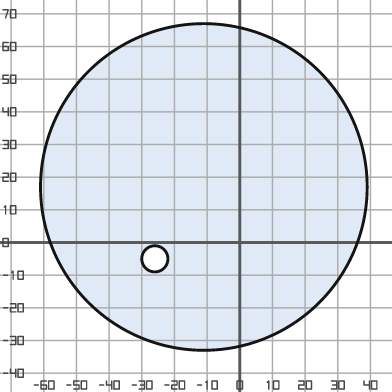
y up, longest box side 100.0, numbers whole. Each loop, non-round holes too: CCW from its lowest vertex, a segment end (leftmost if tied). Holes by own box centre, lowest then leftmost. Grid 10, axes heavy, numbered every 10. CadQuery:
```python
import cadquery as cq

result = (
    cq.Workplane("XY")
    .moveTo(-11.0, 17.0)
    .circle(50.0)
    .moveTo(-26.0, -5.0)
    .circle(4.0)
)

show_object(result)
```